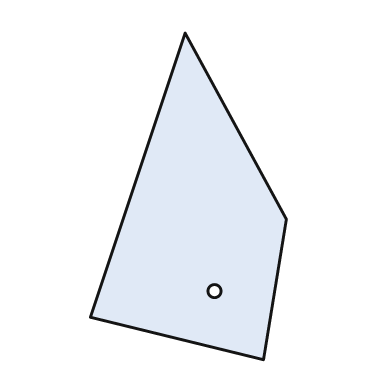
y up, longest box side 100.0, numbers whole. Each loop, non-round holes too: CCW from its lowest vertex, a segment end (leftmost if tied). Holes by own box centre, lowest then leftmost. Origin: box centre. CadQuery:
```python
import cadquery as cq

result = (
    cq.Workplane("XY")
    .moveTo(23.0, -50.0)
    .lineTo(30.0, -7.0)
    .lineTo(-1.0, 50.0)
    .lineTo(-30.0, -37.0)
    .close()
    .moveTo(8.0, -29.0)
    .circle(2.0)
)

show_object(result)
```